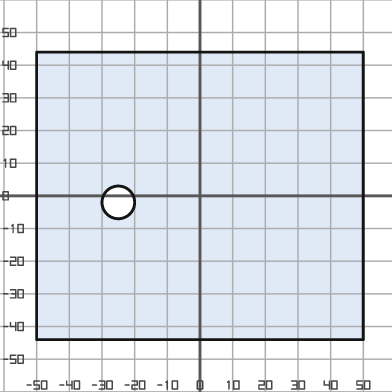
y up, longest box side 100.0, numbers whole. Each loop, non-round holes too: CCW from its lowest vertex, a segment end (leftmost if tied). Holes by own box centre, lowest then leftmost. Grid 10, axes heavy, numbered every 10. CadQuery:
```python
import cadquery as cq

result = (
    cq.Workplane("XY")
    .moveTo(-50.0, -44.0)
    .lineTo(50.0, -44.0)
    .lineTo(50.0, 44.0)
    .lineTo(-50.0, 44.0)
    .close()
    .moveTo(-25.0, -2.0)
    .circle(5.0)
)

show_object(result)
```